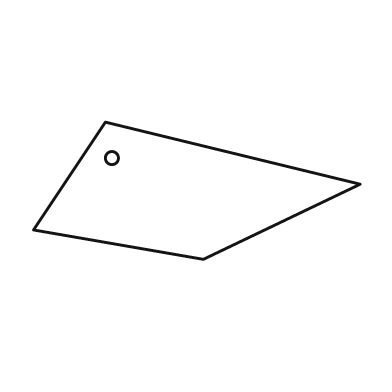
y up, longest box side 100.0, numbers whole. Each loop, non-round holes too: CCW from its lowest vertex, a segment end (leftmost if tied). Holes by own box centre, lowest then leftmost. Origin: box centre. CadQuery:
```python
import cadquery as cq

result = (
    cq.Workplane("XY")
    .moveTo(2.0, -21.0)
    .lineTo(50.0, 2.0)
    .lineTo(-28.0, 21.0)
    .lineTo(-50.0, -12.0)
    .close()
    .moveTo(-26.0, 10.0)
    .circle(2.0)
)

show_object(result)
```